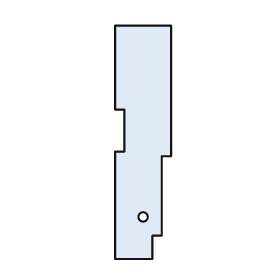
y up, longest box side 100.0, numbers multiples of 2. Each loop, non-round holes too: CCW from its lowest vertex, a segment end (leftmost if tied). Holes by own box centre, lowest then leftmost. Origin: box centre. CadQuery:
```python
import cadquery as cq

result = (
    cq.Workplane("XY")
    .moveTo(-12.0, -50.0)
    .lineTo(4.0, -50.0)
    .lineTo(4.0, -40.0)
    .lineTo(8.0, -40.0)
    .lineTo(8.0, -6.0)
    .lineTo(12.0, -6.0)
    .lineTo(12.0, 50.0)
    .lineTo(-12.0, 50.0)
    .lineTo(-12.0, 14.0)
    .lineTo(-8.0, 14.0)
    .lineTo(-8.0, -4.0)
    .lineTo(-12.0, -4.0)
    .close()
    .moveTo(0.0, -32.0)
    .circle(2.0)
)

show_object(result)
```